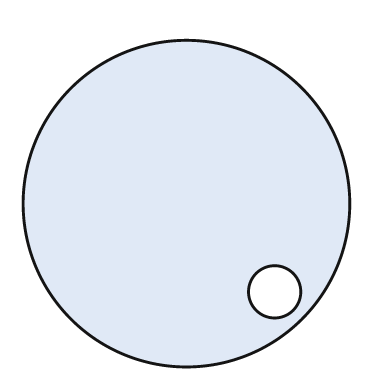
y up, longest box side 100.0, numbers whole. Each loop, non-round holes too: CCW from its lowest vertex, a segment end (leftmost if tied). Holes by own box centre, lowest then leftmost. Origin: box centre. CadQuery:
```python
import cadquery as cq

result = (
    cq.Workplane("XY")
    .moveTo(0.0, 0.0)
    .circle(50.0)
    .moveTo(27.0, -27.0)
    .circle(8.0)
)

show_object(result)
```